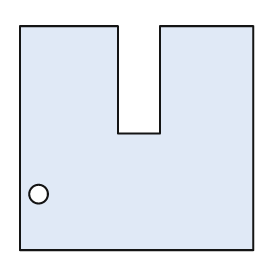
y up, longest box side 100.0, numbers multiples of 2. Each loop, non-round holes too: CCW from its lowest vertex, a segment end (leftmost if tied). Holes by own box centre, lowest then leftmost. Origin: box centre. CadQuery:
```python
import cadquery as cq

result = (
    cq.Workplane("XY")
    .moveTo(-50.0, -48.0)
    .lineTo(50.0, -48.0)
    .lineTo(50.0, 48.0)
    .lineTo(10.0, 48.0)
    .lineTo(10.0, 2.0)
    .lineTo(-8.0, 2.0)
    .lineTo(-8.0, 48.0)
    .lineTo(-50.0, 48.0)
    .close()
    .moveTo(-42.0, -24.0)
    .circle(4.0)
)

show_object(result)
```